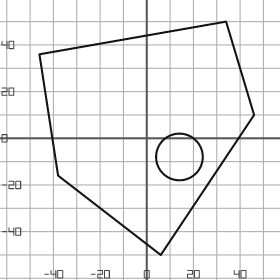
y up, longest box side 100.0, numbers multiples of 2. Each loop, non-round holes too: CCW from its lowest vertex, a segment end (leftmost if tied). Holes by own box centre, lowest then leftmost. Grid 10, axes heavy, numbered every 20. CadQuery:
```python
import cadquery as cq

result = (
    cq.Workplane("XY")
    .moveTo(6.0, -50.0)
    .lineTo(46.0, 10.0)
    .lineTo(34.0, 50.0)
    .lineTo(-46.0, 36.0)
    .lineTo(-38.0, -16.0)
    .close()
    .moveTo(14.0, -8.0)
    .circle(10.0)
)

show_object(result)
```